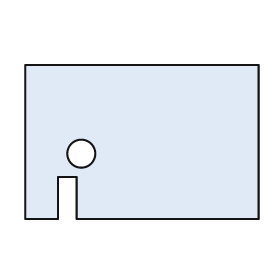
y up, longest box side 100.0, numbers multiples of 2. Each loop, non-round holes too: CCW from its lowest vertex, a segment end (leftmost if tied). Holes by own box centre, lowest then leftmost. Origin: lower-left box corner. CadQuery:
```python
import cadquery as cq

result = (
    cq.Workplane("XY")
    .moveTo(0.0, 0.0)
    .lineTo(14.0, 0.0)
    .lineTo(14.0, 18.0)
    .lineTo(22.0, 18.0)
    .lineTo(22.0, 0.0)
    .lineTo(100.0, 0.0)
    .lineTo(100.0, 66.0)
    .lineTo(0.0, 66.0)
    .close()
    .moveTo(24.0, 28.0)
    .circle(6.0)
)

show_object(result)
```